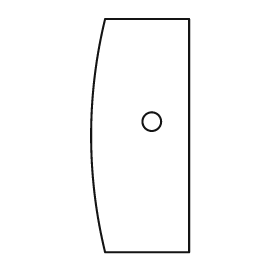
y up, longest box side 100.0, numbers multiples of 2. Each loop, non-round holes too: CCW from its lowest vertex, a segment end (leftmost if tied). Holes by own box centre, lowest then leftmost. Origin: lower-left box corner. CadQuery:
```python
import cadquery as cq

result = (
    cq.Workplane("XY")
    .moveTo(6.0, 0.0)
    .lineTo(42.0, 0.0)
    .lineTo(42.0, 100.0)
    .lineTo(6.0, 100.0)
    .threePointArc((0.0, 50.0), (6.0, 0.0))
    .close()
    .moveTo(26.0, 56.0)
    .circle(4.0)
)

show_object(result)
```